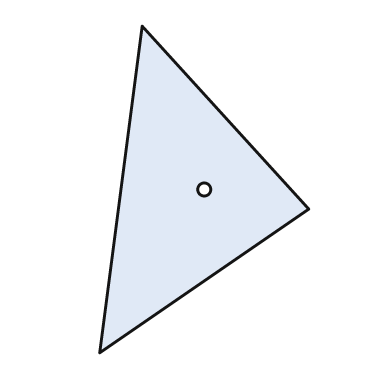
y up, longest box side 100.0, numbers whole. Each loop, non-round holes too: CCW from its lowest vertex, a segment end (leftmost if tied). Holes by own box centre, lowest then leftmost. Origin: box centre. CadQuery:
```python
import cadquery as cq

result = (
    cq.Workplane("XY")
    .moveTo(-32.0, -50.0)
    .lineTo(32.0, -6.0)
    .lineTo(-19.0, 50.0)
    .close()
    .moveTo(0.0, 0.0)
    .circle(2.0)
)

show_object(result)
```